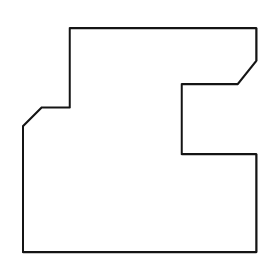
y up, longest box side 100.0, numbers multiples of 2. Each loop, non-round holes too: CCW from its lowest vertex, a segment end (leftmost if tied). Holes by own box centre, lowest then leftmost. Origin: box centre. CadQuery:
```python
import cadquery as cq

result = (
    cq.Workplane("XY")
    .moveTo(-50.0, -48.0)
    .lineTo(50.0, -48.0)
    .lineTo(50.0, -6.0)
    .lineTo(18.0, -6.0)
    .lineTo(18.0, 24.0)
    .lineTo(42.0, 24.0)
    .lineTo(50.0, 34.0)
    .lineTo(50.0, 48.0)
    .lineTo(-30.0, 48.0)
    .lineTo(-30.0, 14.0)
    .lineTo(-42.0, 14.0)
    .lineTo(-50.0, 6.0)
    .close()
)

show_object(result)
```